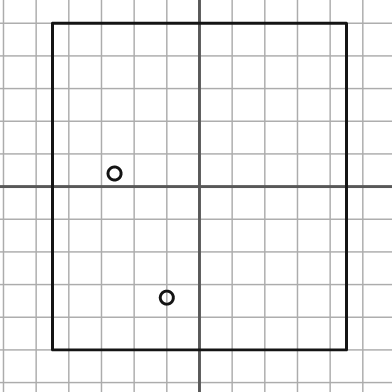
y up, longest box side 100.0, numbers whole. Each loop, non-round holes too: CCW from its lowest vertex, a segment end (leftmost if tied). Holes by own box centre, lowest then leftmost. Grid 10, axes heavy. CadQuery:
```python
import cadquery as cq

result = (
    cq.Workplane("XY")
    .moveTo(-45.0, -50.0)
    .lineTo(45.0, -50.0)
    .lineTo(45.0, 50.0)
    .lineTo(-45.0, 50.0)
    .close()
    .moveTo(-10.0, -34.0)
    .circle(2.0)
    .moveTo(-26.0, 4.0)
    .circle(2.0)
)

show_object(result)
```